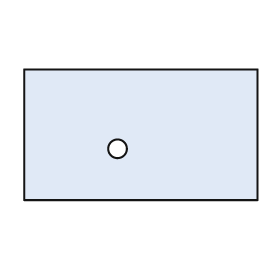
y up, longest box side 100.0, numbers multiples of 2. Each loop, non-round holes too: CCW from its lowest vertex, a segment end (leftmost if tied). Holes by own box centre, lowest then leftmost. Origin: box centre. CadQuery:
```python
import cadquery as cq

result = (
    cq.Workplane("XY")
    .moveTo(-50.0, -28.0)
    .lineTo(50.0, -28.0)
    .lineTo(50.0, 28.0)
    .lineTo(-50.0, 28.0)
    .close()
    .moveTo(-10.0, -6.0)
    .circle(4.0)
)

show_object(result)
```